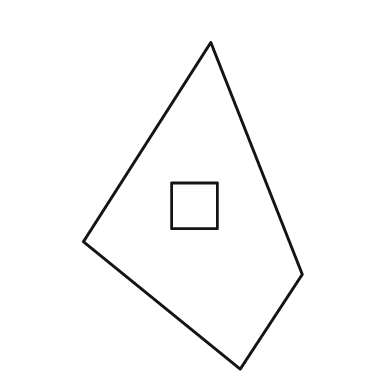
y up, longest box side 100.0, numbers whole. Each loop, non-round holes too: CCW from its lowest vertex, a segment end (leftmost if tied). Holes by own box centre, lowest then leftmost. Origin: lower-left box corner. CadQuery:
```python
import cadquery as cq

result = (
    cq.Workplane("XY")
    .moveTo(48.0, 0.0)
    .lineTo(67.0, 29.0)
    .lineTo(39.0, 100.0)
    .lineTo(0.0, 39.0)
    .close()
    .moveTo(27.0, 43.0)
    .lineTo(41.0, 43.0)
    .lineTo(41.0, 57.0)
    .lineTo(27.0, 57.0)
    .close()
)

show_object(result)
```